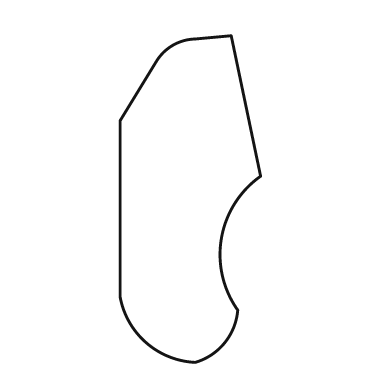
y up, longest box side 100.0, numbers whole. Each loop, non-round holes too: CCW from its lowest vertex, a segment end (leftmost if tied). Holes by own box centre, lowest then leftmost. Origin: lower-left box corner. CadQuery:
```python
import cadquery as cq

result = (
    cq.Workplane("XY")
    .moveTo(23.0, 0.0)
    .threePointArc((32.0, 6.0), (36.0, 16.0))
    .threePointArc((31.0, 38.0), (43.0, 57.0))
    .lineTo(34.0, 100.0)
    .lineTo(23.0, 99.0)
    .threePointArc((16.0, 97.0), (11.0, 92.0))
    .lineTo(0.0, 74.0)
    .lineTo(0.0, 20.0)
    .threePointArc((8.0, 6.0), (23.0, 0.0))
    .close()
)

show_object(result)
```